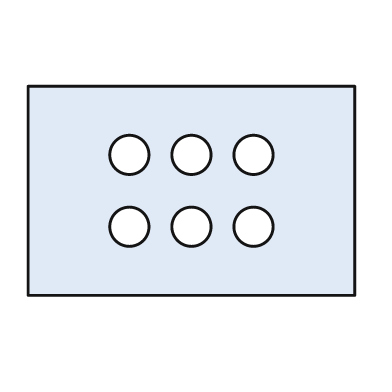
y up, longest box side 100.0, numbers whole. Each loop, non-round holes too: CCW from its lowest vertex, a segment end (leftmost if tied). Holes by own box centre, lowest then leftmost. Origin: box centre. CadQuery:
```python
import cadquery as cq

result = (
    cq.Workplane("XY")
    .moveTo(-50.0, -32.0)
    .lineTo(50.0, -32.0)
    .lineTo(50.0, 32.0)
    .lineTo(-50.0, 32.0)
    .close()
    .moveTo(-19.0, -11.0)
    .circle(6.0)
    .moveTo(0.0, -11.0)
    .circle(6.0)
    .moveTo(19.0, -11.0)
    .circle(6.0)
    .moveTo(-19.0, 11.0)
    .circle(6.0)
    .moveTo(0.0, 11.0)
    .circle(6.0)
    .moveTo(19.0, 11.0)
    .circle(6.0)
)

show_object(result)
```